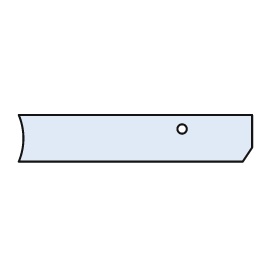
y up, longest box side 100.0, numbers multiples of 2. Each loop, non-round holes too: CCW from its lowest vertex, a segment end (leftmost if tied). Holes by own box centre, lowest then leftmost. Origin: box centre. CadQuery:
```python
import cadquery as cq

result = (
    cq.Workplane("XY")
    .moveTo(-50.0, -10.0)
    .lineTo(46.0, -10.0)
    .lineTo(50.0, -4.0)
    .lineTo(50.0, 10.0)
    .lineTo(-50.0, 10.0)
    .threePointArc((-48.0, 0.0), (-50.0, -10.0))
    .close()
    .moveTo(20.0, 4.0)
    .circle(2.0)
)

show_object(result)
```